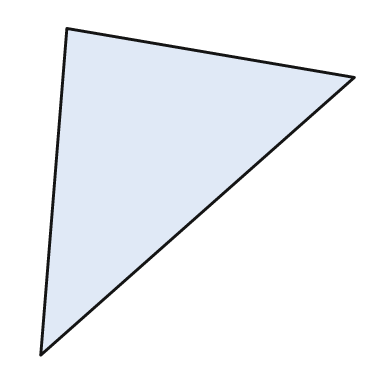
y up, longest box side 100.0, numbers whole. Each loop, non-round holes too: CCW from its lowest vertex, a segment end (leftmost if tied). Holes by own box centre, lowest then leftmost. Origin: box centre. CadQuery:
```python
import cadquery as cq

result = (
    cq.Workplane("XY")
    .moveTo(-48.0, -50.0)
    .lineTo(48.0, 35.0)
    .lineTo(-40.0, 50.0)
    .close()
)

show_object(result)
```